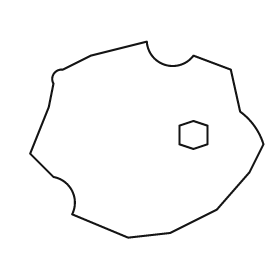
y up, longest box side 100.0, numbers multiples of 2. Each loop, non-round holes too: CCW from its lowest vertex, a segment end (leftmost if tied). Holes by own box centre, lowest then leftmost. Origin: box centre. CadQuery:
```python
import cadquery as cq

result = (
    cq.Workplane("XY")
    .moveTo(-8.0, -42.0)
    .lineTo(10.0, -40.0)
    .lineTo(30.0, -30.0)
    .lineTo(44.0, -14.0)
    .lineTo(50.0, -2.0)
    .threePointArc((46.0, 6.0), (40.0, 12.0))
    .lineTo(36.0, 30.0)
    .lineTo(20.0, 36.0)
    .threePointArc((8.0, 32.0), (0.0, 42.0))
    .lineTo(-24.0, 36.0)
    .lineTo(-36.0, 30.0)
    .threePointArc((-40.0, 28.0), (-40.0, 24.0))
    .lineTo(-42.0, 14.0)
    .lineTo(-50.0, -6.0)
    .lineTo(-40.0, -16.0)
    .threePointArc((-32.0, -22.0), (-32.0, -32.0))
    .close()
    .moveTo(20.0, -4.0)
    .lineTo(26.0, -2.0)
    .lineTo(26.0, 6.0)
    .lineTo(20.0, 8.0)
    .lineTo(14.0, 6.0)
    .lineTo(14.0, -2.0)
    .close()
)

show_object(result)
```